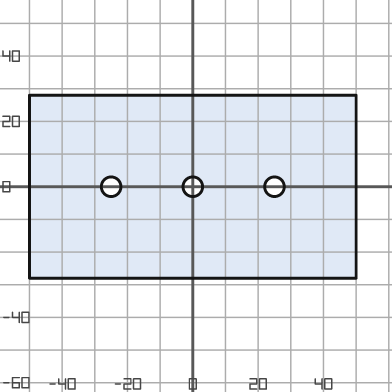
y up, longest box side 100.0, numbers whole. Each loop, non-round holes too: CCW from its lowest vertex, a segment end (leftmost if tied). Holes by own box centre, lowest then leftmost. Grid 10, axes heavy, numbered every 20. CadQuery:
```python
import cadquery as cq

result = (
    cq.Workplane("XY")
    .moveTo(-50.0, -28.0)
    .lineTo(50.0, -28.0)
    .lineTo(50.0, 28.0)
    .lineTo(-50.0, 28.0)
    .close()
    .moveTo(-25.0, 0.0)
    .circle(3.0)
    .moveTo(0.0, 0.0)
    .circle(3.0)
    .moveTo(25.0, 0.0)
    .circle(3.0)
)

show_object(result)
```